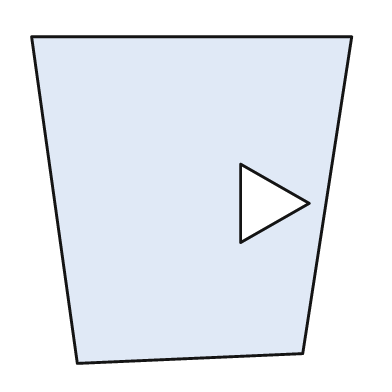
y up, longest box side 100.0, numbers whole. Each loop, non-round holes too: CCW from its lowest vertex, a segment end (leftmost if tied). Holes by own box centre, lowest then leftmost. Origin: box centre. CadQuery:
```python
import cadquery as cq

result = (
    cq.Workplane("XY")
    .moveTo(-35.0, -50.0)
    .lineTo(34.0, -47.0)
    .lineTo(49.0, 50.0)
    .lineTo(-49.0, 50.0)
    .close()
    .moveTo(15.0, -13.0)
    .lineTo(36.0, -1.0)
    .lineTo(15.0, 11.0)
    .close()
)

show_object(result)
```